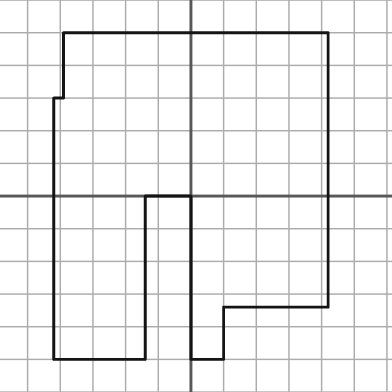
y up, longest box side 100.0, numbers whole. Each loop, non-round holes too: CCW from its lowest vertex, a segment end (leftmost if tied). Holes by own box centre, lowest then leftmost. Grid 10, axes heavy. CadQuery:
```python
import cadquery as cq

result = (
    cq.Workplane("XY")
    .moveTo(-42.0, -50.0)
    .lineTo(-14.0, -50.0)
    .lineTo(-14.0, 0.0)
    .lineTo(0.0, 0.0)
    .lineTo(0.0, -50.0)
    .lineTo(10.0, -50.0)
    .lineTo(10.0, -34.0)
    .lineTo(42.0, -34.0)
    .lineTo(42.0, 50.0)
    .lineTo(-39.0, 50.0)
    .lineTo(-39.0, 30.0)
    .lineTo(-42.0, 30.0)
    .close()
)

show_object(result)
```